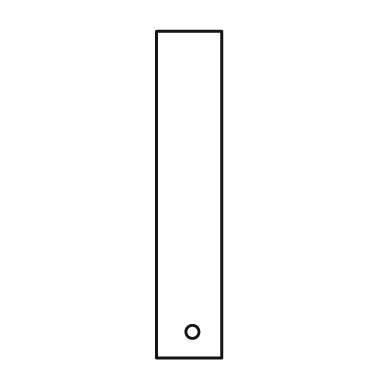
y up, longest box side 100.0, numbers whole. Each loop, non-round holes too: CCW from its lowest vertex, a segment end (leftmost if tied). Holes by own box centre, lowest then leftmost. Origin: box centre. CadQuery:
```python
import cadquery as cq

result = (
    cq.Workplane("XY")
    .moveTo(-10.0, -50.0)
    .lineTo(10.0, -50.0)
    .lineTo(10.0, 50.0)
    .lineTo(-10.0, 50.0)
    .close()
    .moveTo(1.0, -42.0)
    .circle(2.0)
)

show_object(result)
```